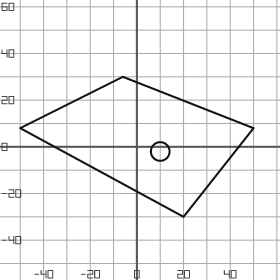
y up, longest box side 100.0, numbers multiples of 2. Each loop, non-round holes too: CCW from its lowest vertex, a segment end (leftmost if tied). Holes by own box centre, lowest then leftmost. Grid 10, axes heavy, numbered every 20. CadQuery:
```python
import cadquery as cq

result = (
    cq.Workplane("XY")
    .moveTo(20.0, -30.0)
    .lineTo(50.0, 8.0)
    .lineTo(-6.0, 30.0)
    .lineTo(-50.0, 8.0)
    .close()
    .moveTo(10.0, -2.0)
    .circle(4.0)
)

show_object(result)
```